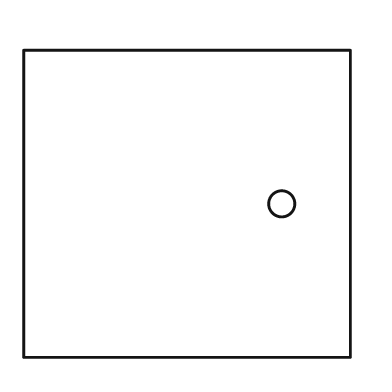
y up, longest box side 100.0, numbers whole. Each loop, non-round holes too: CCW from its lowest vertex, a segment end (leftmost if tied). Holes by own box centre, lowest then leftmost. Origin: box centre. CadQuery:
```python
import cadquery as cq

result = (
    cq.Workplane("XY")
    .moveTo(-50.0, -47.0)
    .lineTo(50.0, -47.0)
    .lineTo(50.0, 47.0)
    .lineTo(-50.0, 47.0)
    .close()
    .moveTo(29.0, 0.0)
    .circle(4.0)
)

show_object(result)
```